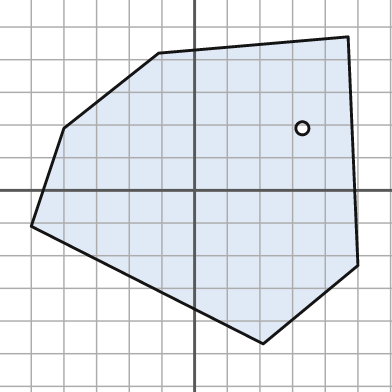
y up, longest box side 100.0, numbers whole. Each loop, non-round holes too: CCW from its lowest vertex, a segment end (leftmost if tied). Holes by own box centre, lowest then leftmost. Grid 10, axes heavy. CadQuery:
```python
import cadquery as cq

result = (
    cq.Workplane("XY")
    .moveTo(21.0, -47.0)
    .lineTo(50.0, -23.0)
    .lineTo(47.0, 47.0)
    .lineTo(-11.0, 42.0)
    .lineTo(-40.0, 19.0)
    .lineTo(-50.0, -11.0)
    .close()
    .moveTo(33.0, 19.0)
    .circle(2.0)
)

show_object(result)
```